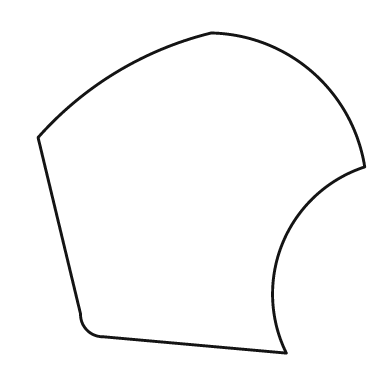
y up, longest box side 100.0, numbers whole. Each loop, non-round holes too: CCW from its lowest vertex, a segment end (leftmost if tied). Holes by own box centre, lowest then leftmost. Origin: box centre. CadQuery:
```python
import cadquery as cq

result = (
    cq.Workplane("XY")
    .moveTo(26.0, -49.0)
    .threePointArc((25.0, -15.0), (50.0, 8.0))
    .threePointArc((34.0, 37.0), (3.0, 49.0))
    .threePointArc((-26.0, 37.0), (-50.0, 17.0))
    .lineTo(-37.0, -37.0)
    .threePointArc((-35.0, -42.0), (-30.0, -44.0))
    .close()
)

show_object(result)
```